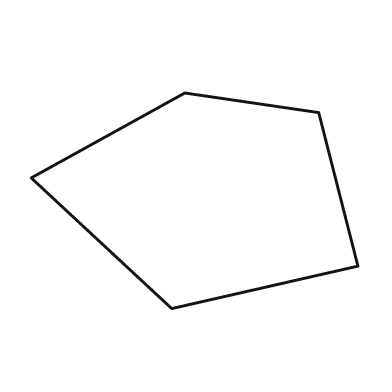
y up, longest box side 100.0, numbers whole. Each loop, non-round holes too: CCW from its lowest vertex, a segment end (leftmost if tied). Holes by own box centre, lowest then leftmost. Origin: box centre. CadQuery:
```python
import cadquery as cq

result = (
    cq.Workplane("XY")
    .moveTo(-7.0, -33.0)
    .lineTo(50.0, -20.0)
    .lineTo(38.0, 27.0)
    .lineTo(-3.0, 33.0)
    .lineTo(-50.0, 7.0)
    .close()
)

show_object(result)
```